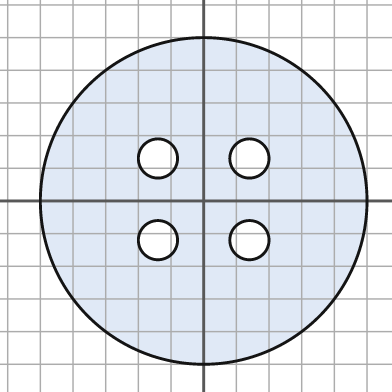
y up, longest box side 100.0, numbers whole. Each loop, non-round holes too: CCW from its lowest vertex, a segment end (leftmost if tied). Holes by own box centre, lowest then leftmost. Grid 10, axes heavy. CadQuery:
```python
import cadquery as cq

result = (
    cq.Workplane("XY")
    .moveTo(0.0, 0.0)
    .circle(50.0)
    .moveTo(-14.0, -12.0)
    .circle(6.0)
    .moveTo(14.0, -12.0)
    .circle(6.0)
    .moveTo(-14.0, 13.0)
    .circle(6.0)
    .moveTo(14.0, 13.0)
    .circle(6.0)
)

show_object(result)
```